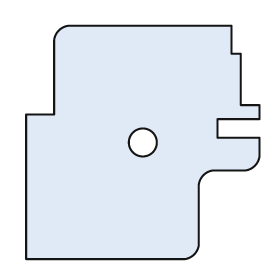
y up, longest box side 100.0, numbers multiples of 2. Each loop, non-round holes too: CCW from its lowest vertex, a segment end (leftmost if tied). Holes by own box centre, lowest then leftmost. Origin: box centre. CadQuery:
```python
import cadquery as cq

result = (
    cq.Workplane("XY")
    .moveTo(-50.0, -50.0)
    .lineTo(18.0, -50.0)
    .threePointArc((22.0, -48.0), (24.0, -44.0))
    .lineTo(24.0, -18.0)
    .threePointArc((26.0, -14.0), (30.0, -12.0))
    .lineTo(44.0, -12.0)
    .threePointArc((48.0, -10.0), (50.0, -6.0))
    .lineTo(50.0, 2.0)
    .lineTo(32.0, 2.0)
    .lineTo(32.0, 10.0)
    .lineTo(50.0, 10.0)
    .lineTo(50.0, 16.0)
    .lineTo(42.0, 16.0)
    .lineTo(42.0, 38.0)
    .lineTo(38.0, 38.0)
    .lineTo(38.0, 50.0)
    .lineTo(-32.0, 50.0)
    .threePointArc((-36.0, 48.0), (-38.0, 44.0))
    .lineTo(-38.0, 12.0)
    .lineTo(-50.0, 12.0)
    .close()
    .moveTo(0.0, 0.0)
    .circle(6.0)
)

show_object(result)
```